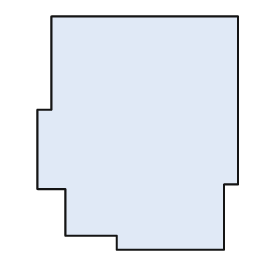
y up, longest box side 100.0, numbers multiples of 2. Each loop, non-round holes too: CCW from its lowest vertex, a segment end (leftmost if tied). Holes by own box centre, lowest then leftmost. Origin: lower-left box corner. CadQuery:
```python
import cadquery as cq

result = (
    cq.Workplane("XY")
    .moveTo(34.0, 0.0)
    .lineTo(80.0, 0.0)
    .lineTo(80.0, 28.0)
    .lineTo(86.0, 28.0)
    .lineTo(86.0, 100.0)
    .lineTo(6.0, 100.0)
    .lineTo(6.0, 60.0)
    .lineTo(0.0, 60.0)
    .lineTo(0.0, 26.0)
    .lineTo(12.0, 26.0)
    .lineTo(12.0, 6.0)
    .lineTo(34.0, 6.0)
    .close()
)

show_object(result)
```